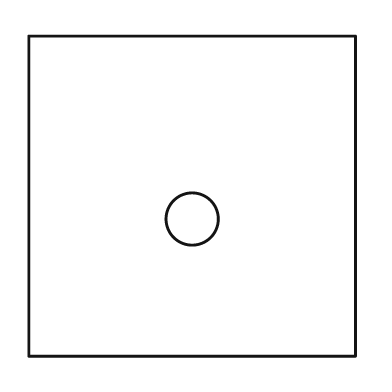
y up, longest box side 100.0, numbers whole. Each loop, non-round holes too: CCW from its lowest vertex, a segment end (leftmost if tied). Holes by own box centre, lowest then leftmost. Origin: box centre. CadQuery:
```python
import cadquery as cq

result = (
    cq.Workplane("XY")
    .moveTo(-50.0, -49.0)
    .lineTo(50.0, -49.0)
    .lineTo(50.0, 49.0)
    .lineTo(-50.0, 49.0)
    .close()
    .moveTo(0.0, -7.0)
    .circle(8.0)
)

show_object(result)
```